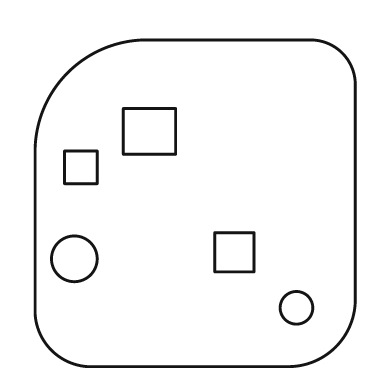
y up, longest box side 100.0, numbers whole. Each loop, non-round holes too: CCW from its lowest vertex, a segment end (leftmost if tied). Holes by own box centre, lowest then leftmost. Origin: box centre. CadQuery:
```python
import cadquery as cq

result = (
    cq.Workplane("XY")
    .moveTo(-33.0, -50.0)
    .lineTo(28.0, -50.0)
    .threePointArc((43.0, -44.0), (49.0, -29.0))
    .lineTo(49.0, 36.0)
    .threePointArc((45.0, 46.0), (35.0, 50.0))
    .lineTo(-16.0, 50.0)
    .threePointArc((-39.0, 40.0), (-49.0, 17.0))
    .lineTo(-49.0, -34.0)
    .threePointArc((-44.0, -45.0), (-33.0, -50.0))
    .close()
    .moveTo(31.0, -32.0)
    .circle(5.0)
    .moveTo(-37.0, -17.0)
    .circle(7.0)
    .moveTo(6.0, -21.0)
    .lineTo(18.0, -21.0)
    .lineTo(18.0, -9.0)
    .lineTo(6.0, -9.0)
    .close()
    .moveTo(-40.0, 6.0)
    .lineTo(-30.0, 6.0)
    .lineTo(-30.0, 16.0)
    .lineTo(-40.0, 16.0)
    .close()
    .moveTo(-22.0, 15.0)
    .lineTo(-6.0, 15.0)
    .lineTo(-6.0, 29.0)
    .lineTo(-22.0, 29.0)
    .close()
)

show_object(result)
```